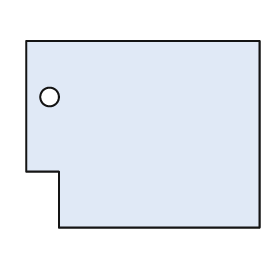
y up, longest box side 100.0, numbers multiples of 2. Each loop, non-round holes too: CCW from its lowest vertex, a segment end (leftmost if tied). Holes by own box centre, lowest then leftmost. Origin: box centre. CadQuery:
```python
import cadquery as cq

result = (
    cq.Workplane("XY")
    .moveTo(-36.0, -40.0)
    .lineTo(50.0, -40.0)
    .lineTo(50.0, 40.0)
    .lineTo(-50.0, 40.0)
    .lineTo(-50.0, -16.0)
    .lineTo(-36.0, -16.0)
    .close()
    .moveTo(-40.0, 16.0)
    .circle(4.0)
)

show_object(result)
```